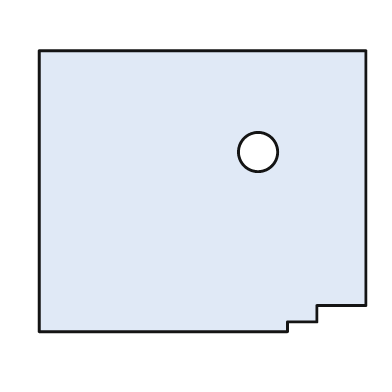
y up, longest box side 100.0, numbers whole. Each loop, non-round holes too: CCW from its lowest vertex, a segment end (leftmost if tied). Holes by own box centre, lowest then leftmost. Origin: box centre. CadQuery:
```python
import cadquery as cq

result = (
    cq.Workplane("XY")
    .moveTo(-50.0, -43.0)
    .lineTo(26.0, -43.0)
    .lineTo(26.0, -40.0)
    .lineTo(35.0, -40.0)
    .lineTo(35.0, -35.0)
    .lineTo(50.0, -35.0)
    .lineTo(50.0, 43.0)
    .lineTo(-50.0, 43.0)
    .close()
    .moveTo(17.0, 12.0)
    .circle(6.0)
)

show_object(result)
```